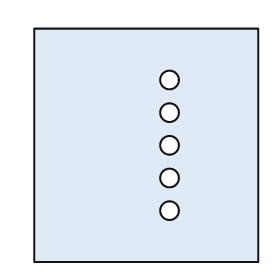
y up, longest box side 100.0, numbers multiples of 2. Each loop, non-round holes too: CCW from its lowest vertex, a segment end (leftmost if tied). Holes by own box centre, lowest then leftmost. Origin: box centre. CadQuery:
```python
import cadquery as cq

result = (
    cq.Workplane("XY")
    .moveTo(-48.0, -50.0)
    .lineTo(48.0, -50.0)
    .lineTo(48.0, 50.0)
    .lineTo(-48.0, 50.0)
    .close()
    .moveTo(10.0, -28.0)
    .circle(4.0)
    .moveTo(10.0, -14.0)
    .circle(4.0)
    .moveTo(10.0, 0.0)
    .circle(4.0)
    .moveTo(10.0, 14.0)
    .circle(4.0)
    .moveTo(10.0, 28.0)
    .circle(4.0)
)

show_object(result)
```